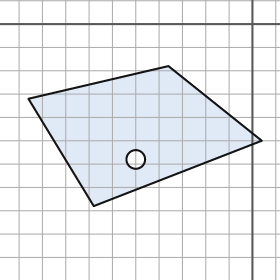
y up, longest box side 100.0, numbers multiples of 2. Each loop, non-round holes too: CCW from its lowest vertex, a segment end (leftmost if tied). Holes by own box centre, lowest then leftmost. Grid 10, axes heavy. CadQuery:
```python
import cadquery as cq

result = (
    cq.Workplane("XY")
    .moveTo(-68.0, -78.0)
    .lineTo(4.0, -50.0)
    .lineTo(-36.0, -18.0)
    .lineTo(-96.0, -32.0)
    .close()
    .moveTo(-50.0, -58.0)
    .circle(4.0)
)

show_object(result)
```